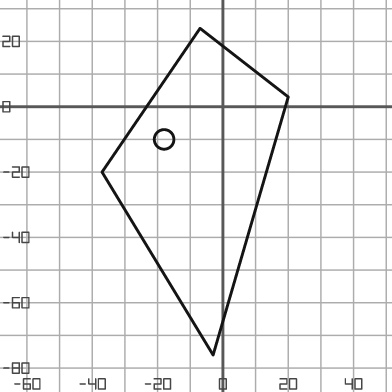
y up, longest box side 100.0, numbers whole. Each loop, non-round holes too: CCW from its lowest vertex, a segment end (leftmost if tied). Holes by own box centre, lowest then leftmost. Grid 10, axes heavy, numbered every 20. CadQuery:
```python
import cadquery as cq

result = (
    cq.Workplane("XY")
    .moveTo(-3.0, -76.0)
    .lineTo(20.0, 3.0)
    .lineTo(-7.0, 24.0)
    .lineTo(-37.0, -20.0)
    .close()
    .moveTo(-18.0, -10.0)
    .circle(3.0)
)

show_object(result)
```